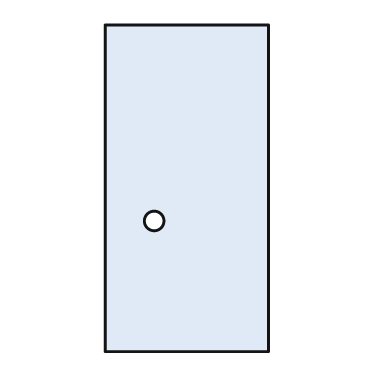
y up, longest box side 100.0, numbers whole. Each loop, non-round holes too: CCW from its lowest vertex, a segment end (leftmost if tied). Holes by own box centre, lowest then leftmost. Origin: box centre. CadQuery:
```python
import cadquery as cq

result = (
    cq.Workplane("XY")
    .moveTo(-25.0, -50.0)
    .lineTo(25.0, -50.0)
    .lineTo(25.0, 50.0)
    .lineTo(-25.0, 50.0)
    .close()
    .moveTo(-10.0, -10.0)
    .circle(3.0)
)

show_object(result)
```